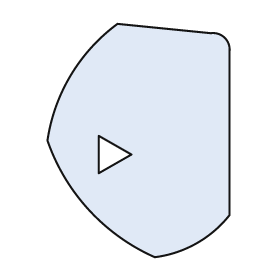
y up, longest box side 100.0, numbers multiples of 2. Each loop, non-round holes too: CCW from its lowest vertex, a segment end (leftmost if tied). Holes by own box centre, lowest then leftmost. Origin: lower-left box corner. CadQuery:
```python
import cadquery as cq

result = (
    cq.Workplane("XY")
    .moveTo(46.0, 0.0)
    .threePointArc((64.0, 6.0), (78.0, 18.0))
    .lineTo(78.0, 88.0)
    .threePointArc((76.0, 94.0), (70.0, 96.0))
    .lineTo(30.0, 100.0)
    .threePointArc((10.0, 78.0), (0.0, 50.0))
    .threePointArc((18.0, 20.0), (46.0, 0.0))
    .close()
    .moveTo(22.0, 36.0)
    .lineTo(36.0, 44.0)
    .lineTo(22.0, 52.0)
    .close()
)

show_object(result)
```